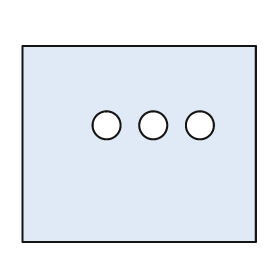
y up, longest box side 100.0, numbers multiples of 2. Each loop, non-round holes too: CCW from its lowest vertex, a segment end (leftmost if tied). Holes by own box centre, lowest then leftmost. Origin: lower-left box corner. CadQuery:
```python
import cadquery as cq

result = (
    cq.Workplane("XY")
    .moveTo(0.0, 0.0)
    .lineTo(100.0, 0.0)
    .lineTo(100.0, 84.0)
    .lineTo(0.0, 84.0)
    .close()
    .moveTo(36.0, 50.0)
    .circle(6.0)
    .moveTo(56.0, 50.0)
    .circle(6.0)
    .moveTo(76.0, 50.0)
    .circle(6.0)
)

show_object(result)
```